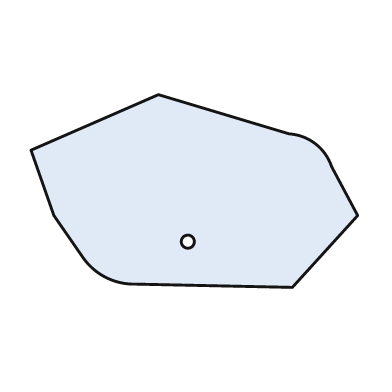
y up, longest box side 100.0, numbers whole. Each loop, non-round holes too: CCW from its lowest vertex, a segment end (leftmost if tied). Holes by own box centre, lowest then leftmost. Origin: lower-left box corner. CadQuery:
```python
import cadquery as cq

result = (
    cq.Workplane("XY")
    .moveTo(80.0, 0.0)
    .lineTo(100.0, 22.0)
    .lineTo(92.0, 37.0)
    .threePointArc((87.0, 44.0), (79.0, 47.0))
    .lineTo(39.0, 59.0)
    .lineTo(0.0, 42.0)
    .lineTo(7.0, 22.0)
    .lineTo(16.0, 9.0)
    .threePointArc((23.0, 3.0), (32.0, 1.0))
    .close()
    .moveTo(48.0, 14.0)
    .circle(2.0)
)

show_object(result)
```